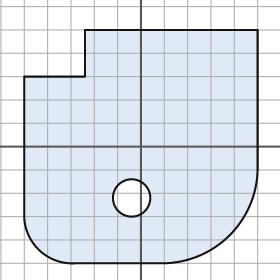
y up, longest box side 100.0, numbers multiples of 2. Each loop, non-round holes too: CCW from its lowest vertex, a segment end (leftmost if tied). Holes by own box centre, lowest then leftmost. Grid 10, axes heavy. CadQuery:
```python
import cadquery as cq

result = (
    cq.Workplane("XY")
    .moveTo(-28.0, -50.0)
    .lineTo(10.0, -50.0)
    .threePointArc((38.0, -38.0), (50.0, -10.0))
    .lineTo(50.0, 50.0)
    .lineTo(-24.0, 50.0)
    .lineTo(-24.0, 30.0)
    .lineTo(-50.0, 30.0)
    .lineTo(-50.0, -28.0)
    .threePointArc((-44.0, -44.0), (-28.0, -50.0))
    .close()
    .moveTo(-4.0, -22.0)
    .circle(8.0)
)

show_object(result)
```